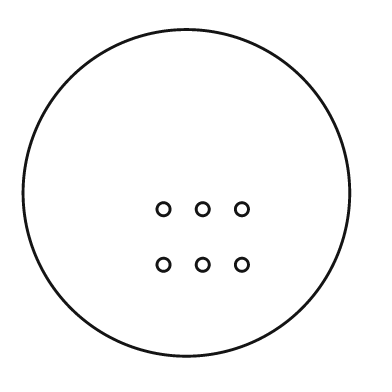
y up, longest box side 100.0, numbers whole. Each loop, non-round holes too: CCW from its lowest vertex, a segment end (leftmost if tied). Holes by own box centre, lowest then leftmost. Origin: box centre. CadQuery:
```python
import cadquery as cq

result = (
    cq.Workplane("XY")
    .moveTo(0.0, 0.0)
    .circle(50.0)
    .moveTo(-7.0, -22.0)
    .circle(2.0)
    .moveTo(5.0, -22.0)
    .circle(2.0)
    .moveTo(17.0, -22.0)
    .circle(2.0)
    .moveTo(-7.0, -5.0)
    .circle(2.0)
    .moveTo(5.0, -5.0)
    .circle(2.0)
    .moveTo(17.0, -5.0)
    .circle(2.0)
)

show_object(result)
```